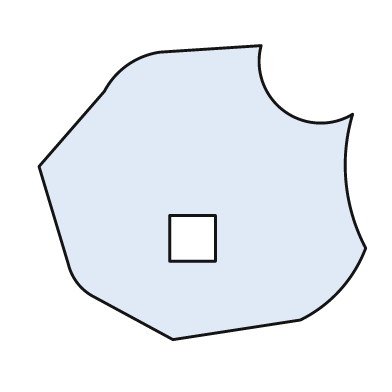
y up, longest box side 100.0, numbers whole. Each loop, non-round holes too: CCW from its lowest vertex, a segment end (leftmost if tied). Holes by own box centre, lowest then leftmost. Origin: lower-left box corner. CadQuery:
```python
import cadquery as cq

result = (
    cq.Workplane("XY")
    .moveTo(41.0, 0.0)
    .lineTo(80.0, 6.0)
    .threePointArc((92.0, 15.0), (100.0, 28.0))
    .threePointArc((94.0, 48.0), (96.0, 69.0))
    .threePointArc((75.0, 70.0), (68.0, 90.0))
    .lineTo(37.0, 88.0)
    .threePointArc((27.0, 84.0), (20.0, 76.0))
    .lineTo(0.0, 53.0)
    .lineTo(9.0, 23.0)
    .threePointArc((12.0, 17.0), (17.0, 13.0))
    .close()
    .moveTo(40.0, 24.0)
    .lineTo(54.0, 24.0)
    .lineTo(54.0, 38.0)
    .lineTo(40.0, 38.0)
    .close()
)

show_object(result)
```